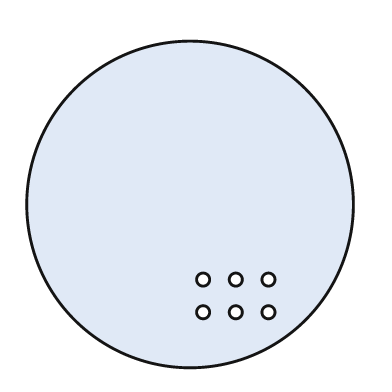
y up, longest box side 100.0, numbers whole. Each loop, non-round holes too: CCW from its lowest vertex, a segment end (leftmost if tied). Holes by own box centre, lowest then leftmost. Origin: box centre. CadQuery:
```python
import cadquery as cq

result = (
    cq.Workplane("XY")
    .moveTo(0.0, 0.0)
    .circle(50.0)
    .moveTo(4.0, -33.0)
    .circle(2.0)
    .moveTo(14.0, -33.0)
    .circle(2.0)
    .moveTo(24.0, -33.0)
    .circle(2.0)
    .moveTo(4.0, -23.0)
    .circle(2.0)
    .moveTo(14.0, -23.0)
    .circle(2.0)
    .moveTo(24.0, -23.0)
    .circle(2.0)
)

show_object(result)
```